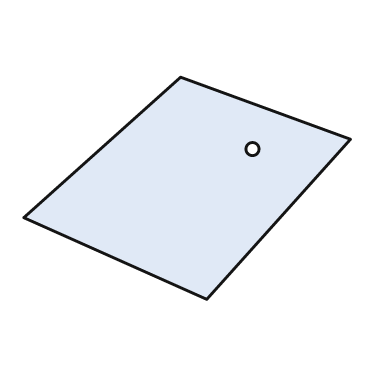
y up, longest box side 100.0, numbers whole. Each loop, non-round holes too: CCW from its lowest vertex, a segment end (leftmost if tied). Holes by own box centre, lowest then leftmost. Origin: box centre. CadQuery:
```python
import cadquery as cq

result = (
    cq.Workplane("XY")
    .moveTo(6.0, -34.0)
    .lineTo(50.0, 15.0)
    .lineTo(-2.0, 34.0)
    .lineTo(-50.0, -9.0)
    .close()
    .moveTo(20.0, 12.0)
    .circle(2.0)
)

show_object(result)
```